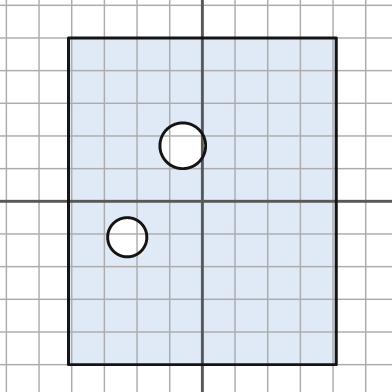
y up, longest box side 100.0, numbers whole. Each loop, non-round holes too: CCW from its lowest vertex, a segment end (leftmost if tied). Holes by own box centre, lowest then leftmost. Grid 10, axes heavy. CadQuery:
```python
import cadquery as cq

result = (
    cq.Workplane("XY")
    .moveTo(-41.0, -50.0)
    .lineTo(41.0, -50.0)
    .lineTo(41.0, 50.0)
    .lineTo(-41.0, 50.0)
    .close()
    .moveTo(-23.0, -11.0)
    .circle(6.0)
    .moveTo(-6.0, 17.0)
    .circle(7.0)
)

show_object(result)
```